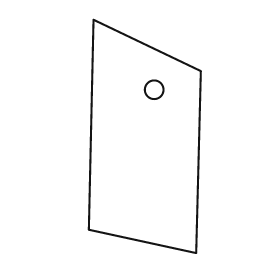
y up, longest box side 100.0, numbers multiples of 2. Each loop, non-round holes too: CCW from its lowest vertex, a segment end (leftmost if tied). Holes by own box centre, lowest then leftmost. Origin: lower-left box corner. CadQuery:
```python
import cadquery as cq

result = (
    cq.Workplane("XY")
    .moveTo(46.0, 0.0)
    .lineTo(48.0, 78.0)
    .lineTo(2.0, 100.0)
    .lineTo(0.0, 10.0)
    .close()
    .moveTo(28.0, 70.0)
    .circle(4.0)
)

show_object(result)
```